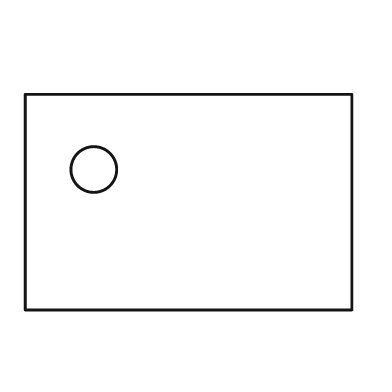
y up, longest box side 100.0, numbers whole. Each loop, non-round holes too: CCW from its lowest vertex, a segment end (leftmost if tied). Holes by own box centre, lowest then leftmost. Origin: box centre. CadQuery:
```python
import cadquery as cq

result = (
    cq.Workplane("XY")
    .moveTo(-50.0, -33.0)
    .lineTo(50.0, -33.0)
    .lineTo(50.0, 33.0)
    .lineTo(-50.0, 33.0)
    .close()
    .moveTo(-29.0, 10.0)
    .circle(7.0)
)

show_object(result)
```